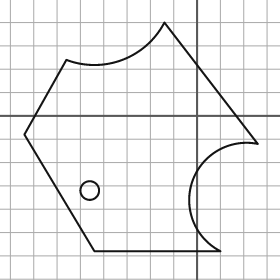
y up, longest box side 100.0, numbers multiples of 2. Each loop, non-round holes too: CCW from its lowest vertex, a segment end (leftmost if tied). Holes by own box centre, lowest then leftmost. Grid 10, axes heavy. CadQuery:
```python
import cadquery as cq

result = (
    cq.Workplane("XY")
    .moveTo(-44.0, -58.0)
    .lineTo(10.0, -58.0)
    .threePointArc((-2.0, -28.0), (26.0, -12.0))
    .lineTo(-14.0, 40.0)
    .threePointArc((-32.0, 24.0), (-56.0, 24.0))
    .lineTo(-74.0, -8.0)
    .close()
    .moveTo(-46.0, -32.0)
    .circle(4.0)
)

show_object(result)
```